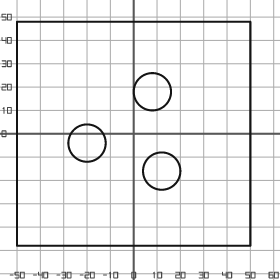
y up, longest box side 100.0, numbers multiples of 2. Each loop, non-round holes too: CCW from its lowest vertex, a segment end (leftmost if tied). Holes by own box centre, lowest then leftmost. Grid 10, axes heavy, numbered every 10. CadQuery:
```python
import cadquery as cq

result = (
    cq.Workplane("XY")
    .moveTo(-50.0, -48.0)
    .lineTo(50.0, -48.0)
    .lineTo(50.0, 48.0)
    .lineTo(-50.0, 48.0)
    .close()
    .moveTo(12.0, -16.0)
    .circle(8.0)
    .moveTo(-20.0, -4.0)
    .circle(8.0)
    .moveTo(8.0, 18.0)
    .circle(8.0)
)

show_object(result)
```